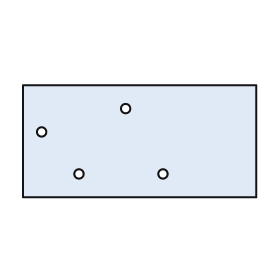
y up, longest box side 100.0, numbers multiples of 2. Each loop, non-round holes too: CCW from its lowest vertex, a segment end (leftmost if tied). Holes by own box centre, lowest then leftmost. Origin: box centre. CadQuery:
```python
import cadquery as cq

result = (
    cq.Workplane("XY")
    .moveTo(-50.0, -24.0)
    .lineTo(50.0, -24.0)
    .lineTo(50.0, 24.0)
    .lineTo(-50.0, 24.0)
    .close()
    .moveTo(-26.0, -14.0)
    .circle(2.0)
    .moveTo(10.0, -14.0)
    .circle(2.0)
    .moveTo(-42.0, 4.0)
    .circle(2.0)
    .moveTo(-6.0, 14.0)
    .circle(2.0)
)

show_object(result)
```